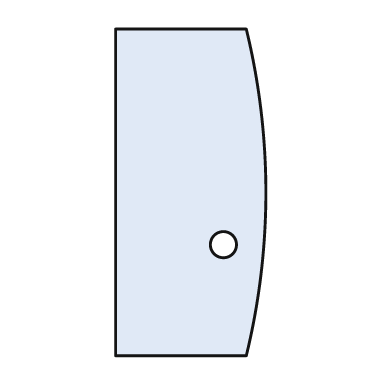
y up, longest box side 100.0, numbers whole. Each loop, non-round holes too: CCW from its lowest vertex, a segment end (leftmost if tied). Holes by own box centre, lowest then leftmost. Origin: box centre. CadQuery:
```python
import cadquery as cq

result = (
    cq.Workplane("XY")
    .moveTo(-23.0, -50.0)
    .lineTo(17.0, -50.0)
    .threePointArc((23.0, 0.0), (17.0, 50.0))
    .lineTo(-23.0, 50.0)
    .close()
    .moveTo(10.0, -16.0)
    .circle(4.0)
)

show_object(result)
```